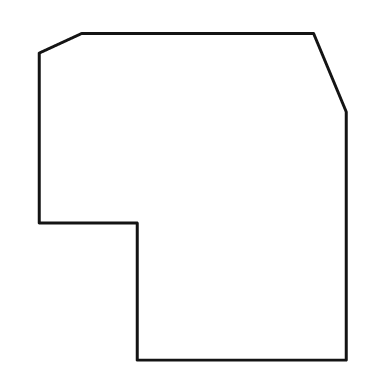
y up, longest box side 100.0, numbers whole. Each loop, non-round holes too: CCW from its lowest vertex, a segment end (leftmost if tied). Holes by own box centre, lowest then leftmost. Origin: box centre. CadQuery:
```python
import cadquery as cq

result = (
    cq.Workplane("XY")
    .moveTo(-17.0, -50.0)
    .lineTo(47.0, -50.0)
    .lineTo(47.0, 26.0)
    .lineTo(37.0, 50.0)
    .lineTo(-34.0, 50.0)
    .lineTo(-47.0, 44.0)
    .lineTo(-47.0, -8.0)
    .lineTo(-17.0, -8.0)
    .close()
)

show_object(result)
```